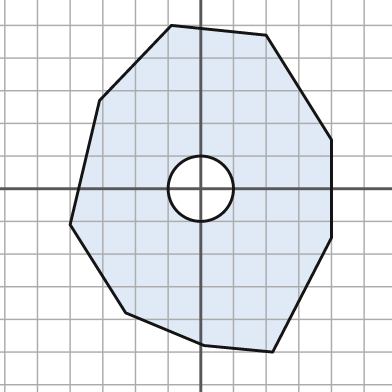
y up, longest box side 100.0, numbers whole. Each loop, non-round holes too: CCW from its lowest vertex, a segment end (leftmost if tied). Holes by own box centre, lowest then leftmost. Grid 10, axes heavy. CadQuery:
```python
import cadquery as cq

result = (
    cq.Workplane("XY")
    .moveTo(22.0, -50.0)
    .lineTo(40.0, -15.0)
    .lineTo(40.0, 15.0)
    .lineTo(20.0, 47.0)
    .lineTo(-9.0, 50.0)
    .lineTo(-31.0, 27.0)
    .lineTo(-40.0, -11.0)
    .lineTo(-23.0, -38.0)
    .lineTo(1.0, -48.0)
    .close()
    .moveTo(0.0, 0.0)
    .circle(10.0)
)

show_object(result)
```